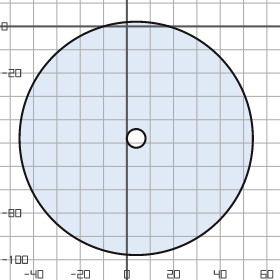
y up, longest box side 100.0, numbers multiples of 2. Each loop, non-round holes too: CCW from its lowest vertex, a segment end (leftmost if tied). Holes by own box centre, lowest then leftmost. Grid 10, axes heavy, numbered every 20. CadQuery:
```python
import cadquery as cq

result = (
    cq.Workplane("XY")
    .moveTo(4.0, -48.0)
    .circle(50.0)
    .moveTo(4.0, -48.0)
    .circle(4.0)
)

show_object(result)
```